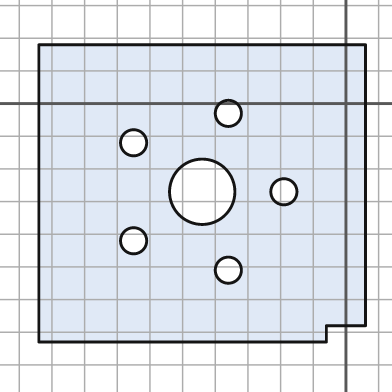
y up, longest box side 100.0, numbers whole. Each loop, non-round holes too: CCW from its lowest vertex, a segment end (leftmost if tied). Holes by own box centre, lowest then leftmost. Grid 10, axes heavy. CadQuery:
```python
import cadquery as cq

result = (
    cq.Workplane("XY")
    .moveTo(-94.0, -73.0)
    .lineTo(-6.0, -73.0)
    .lineTo(-6.0, -68.0)
    .lineTo(6.0, -68.0)
    .lineTo(6.0, 18.0)
    .lineTo(-94.0, 18.0)
    .close()
    .moveTo(-36.0, -51.0)
    .circle(4.0)
    .moveTo(-65.0, -42.0)
    .circle(4.0)
    .moveTo(-44.0, -27.0)
    .circle(10.0)
    .moveTo(-19.0, -27.0)
    .circle(4.0)
    .moveTo(-65.0, -12.0)
    .circle(4.0)
    .moveTo(-36.0, -3.0)
    .circle(4.0)
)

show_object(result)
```